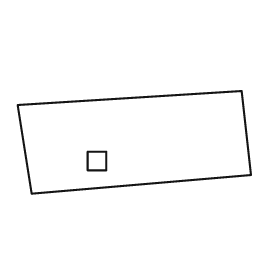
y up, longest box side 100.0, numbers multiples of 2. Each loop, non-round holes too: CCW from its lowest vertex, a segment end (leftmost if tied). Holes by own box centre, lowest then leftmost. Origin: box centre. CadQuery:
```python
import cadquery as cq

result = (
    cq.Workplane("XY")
    .moveTo(-44.0, -22.0)
    .lineTo(50.0, -14.0)
    .lineTo(46.0, 22.0)
    .lineTo(-50.0, 16.0)
    .close()
    .moveTo(-20.0, -12.0)
    .lineTo(-12.0, -12.0)
    .lineTo(-12.0, -4.0)
    .lineTo(-20.0, -4.0)
    .close()
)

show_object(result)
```